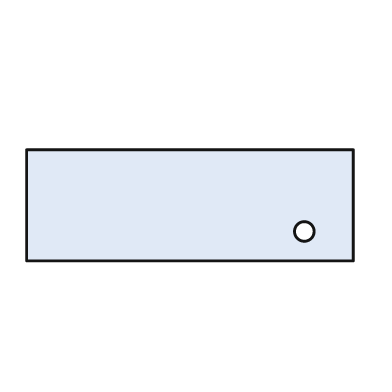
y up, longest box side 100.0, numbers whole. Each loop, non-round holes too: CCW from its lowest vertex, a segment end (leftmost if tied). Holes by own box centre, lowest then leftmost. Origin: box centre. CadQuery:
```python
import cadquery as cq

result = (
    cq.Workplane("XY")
    .moveTo(-50.0, -17.0)
    .lineTo(50.0, -17.0)
    .lineTo(50.0, 17.0)
    .lineTo(-50.0, 17.0)
    .close()
    .moveTo(35.0, -8.0)
    .circle(3.0)
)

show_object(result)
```